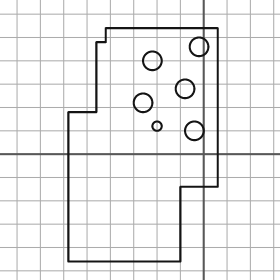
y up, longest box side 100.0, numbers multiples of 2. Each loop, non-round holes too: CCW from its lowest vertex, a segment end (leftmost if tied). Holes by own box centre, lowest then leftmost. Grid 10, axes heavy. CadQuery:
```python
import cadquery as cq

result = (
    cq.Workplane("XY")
    .moveTo(-58.0, -46.0)
    .lineTo(-10.0, -46.0)
    .lineTo(-10.0, -14.0)
    .lineTo(6.0, -14.0)
    .lineTo(6.0, 54.0)
    .lineTo(-42.0, 54.0)
    .lineTo(-42.0, 48.0)
    .lineTo(-46.0, 48.0)
    .lineTo(-46.0, 18.0)
    .lineTo(-58.0, 18.0)
    .close()
    .moveTo(-4.0, 10.0)
    .circle(4.0)
    .moveTo(-20.0, 12.0)
    .circle(2.0)
    .moveTo(-26.0, 22.0)
    .circle(4.0)
    .moveTo(-8.0, 28.0)
    .circle(4.0)
    .moveTo(-22.0, 40.0)
    .circle(4.0)
    .moveTo(-2.0, 46.0)
    .circle(4.0)
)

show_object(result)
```